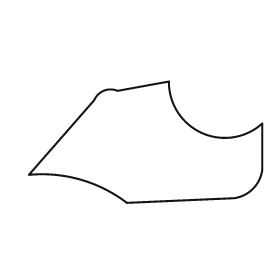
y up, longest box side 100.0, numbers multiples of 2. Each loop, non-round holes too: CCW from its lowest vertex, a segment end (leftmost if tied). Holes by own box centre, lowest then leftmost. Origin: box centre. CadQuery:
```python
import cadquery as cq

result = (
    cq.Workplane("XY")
    .moveTo(-8.0, -26.0)
    .lineTo(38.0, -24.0)
    .threePointArc((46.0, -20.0), (50.0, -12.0))
    .lineTo(50.0, 8.0)
    .threePointArc((24.0, 4.0), (10.0, 26.0))
    .lineTo(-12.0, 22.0)
    .threePointArc((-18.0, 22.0), (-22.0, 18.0))
    .lineTo(-50.0, -14.0)
    .threePointArc((-28.0, -16.0), (-8.0, -26.0))
    .close()
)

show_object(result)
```